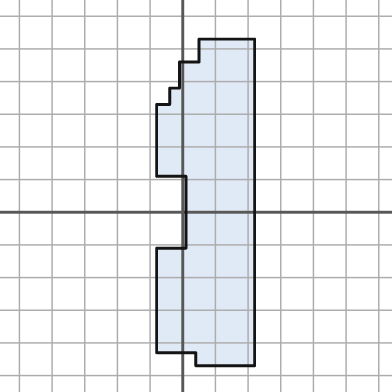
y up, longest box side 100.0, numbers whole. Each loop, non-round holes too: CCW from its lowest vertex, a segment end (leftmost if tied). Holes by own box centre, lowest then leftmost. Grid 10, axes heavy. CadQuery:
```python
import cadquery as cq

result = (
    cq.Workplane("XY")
    .moveTo(4.0, -47.0)
    .lineTo(22.0, -47.0)
    .lineTo(22.0, 53.0)
    .lineTo(5.0, 53.0)
    .lineTo(5.0, 46.0)
    .lineTo(-1.0, 46.0)
    .lineTo(-1.0, 38.0)
    .lineTo(-4.0, 38.0)
    .lineTo(-4.0, 33.0)
    .lineTo(-8.0, 33.0)
    .lineTo(-8.0, 11.0)
    .lineTo(1.0, 11.0)
    .lineTo(1.0, -11.0)
    .lineTo(-8.0, -11.0)
    .lineTo(-8.0, -43.0)
    .lineTo(4.0, -43.0)
    .close()
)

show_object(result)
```